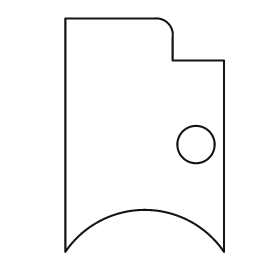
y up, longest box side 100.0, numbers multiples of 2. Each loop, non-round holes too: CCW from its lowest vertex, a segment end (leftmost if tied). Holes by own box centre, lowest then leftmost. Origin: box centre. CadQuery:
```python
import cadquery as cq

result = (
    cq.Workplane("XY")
    .moveTo(-34.0, -50.0)
    .threePointArc((0.0, -32.0), (34.0, -50.0))
    .lineTo(34.0, 32.0)
    .lineTo(12.0, 32.0)
    .lineTo(12.0, 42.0)
    .threePointArc((10.0, 48.0), (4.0, 50.0))
    .lineTo(-34.0, 50.0)
    .close()
    .moveTo(22.0, -4.0)
    .circle(8.0)
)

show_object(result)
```